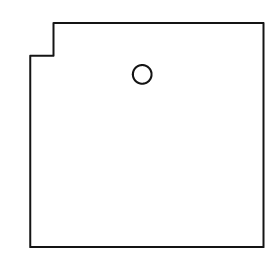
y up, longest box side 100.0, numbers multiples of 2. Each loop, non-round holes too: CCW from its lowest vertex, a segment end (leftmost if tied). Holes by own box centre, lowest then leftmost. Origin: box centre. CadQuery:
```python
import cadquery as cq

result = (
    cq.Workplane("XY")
    .moveTo(-50.0, -48.0)
    .lineTo(50.0, -48.0)
    .lineTo(50.0, 48.0)
    .lineTo(-40.0, 48.0)
    .lineTo(-40.0, 34.0)
    .lineTo(-50.0, 34.0)
    .close()
    .moveTo(-2.0, 26.0)
    .circle(4.0)
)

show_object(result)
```